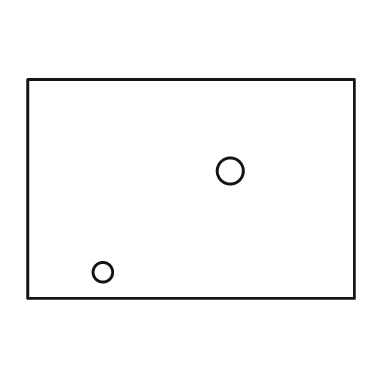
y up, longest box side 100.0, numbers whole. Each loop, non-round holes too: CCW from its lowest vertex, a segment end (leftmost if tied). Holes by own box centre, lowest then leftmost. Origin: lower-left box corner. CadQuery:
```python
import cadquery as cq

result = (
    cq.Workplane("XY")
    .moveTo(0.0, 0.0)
    .lineTo(100.0, 0.0)
    .lineTo(100.0, 67.0)
    .lineTo(0.0, 67.0)
    .close()
    .moveTo(23.0, 8.0)
    .circle(3.0)
    .moveTo(62.0, 39.0)
    .circle(4.0)
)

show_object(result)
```